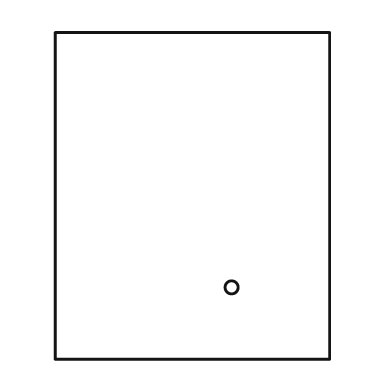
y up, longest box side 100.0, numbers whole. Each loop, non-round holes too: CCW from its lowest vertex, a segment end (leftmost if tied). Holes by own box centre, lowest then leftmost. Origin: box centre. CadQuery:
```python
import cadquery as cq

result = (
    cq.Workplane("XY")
    .moveTo(-42.0, -50.0)
    .lineTo(42.0, -50.0)
    .lineTo(42.0, 50.0)
    .lineTo(-42.0, 50.0)
    .close()
    .moveTo(12.0, -28.0)
    .circle(2.0)
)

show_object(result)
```